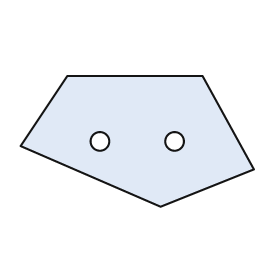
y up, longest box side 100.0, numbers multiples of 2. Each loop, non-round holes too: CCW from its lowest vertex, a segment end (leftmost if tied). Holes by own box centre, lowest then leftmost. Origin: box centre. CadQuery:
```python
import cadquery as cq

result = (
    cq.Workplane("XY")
    .moveTo(10.0, -28.0)
    .lineTo(50.0, -12.0)
    .lineTo(28.0, 28.0)
    .lineTo(-30.0, 28.0)
    .lineTo(-50.0, -2.0)
    .close()
    .moveTo(-16.0, 0.0)
    .circle(4.0)
    .moveTo(16.0, 0.0)
    .circle(4.0)
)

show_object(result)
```